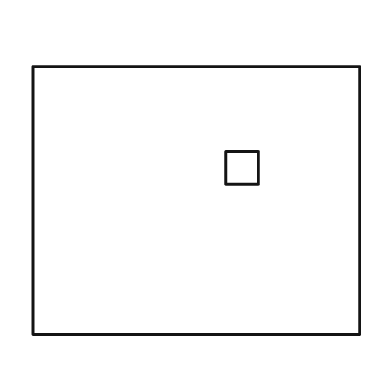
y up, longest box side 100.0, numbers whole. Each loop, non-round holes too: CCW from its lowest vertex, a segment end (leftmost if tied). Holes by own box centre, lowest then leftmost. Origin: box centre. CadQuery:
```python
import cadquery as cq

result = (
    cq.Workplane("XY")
    .moveTo(-50.0, -41.0)
    .lineTo(50.0, -41.0)
    .lineTo(50.0, 41.0)
    .lineTo(-50.0, 41.0)
    .close()
    .moveTo(9.0, 5.0)
    .lineTo(19.0, 5.0)
    .lineTo(19.0, 15.0)
    .lineTo(9.0, 15.0)
    .close()
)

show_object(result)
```